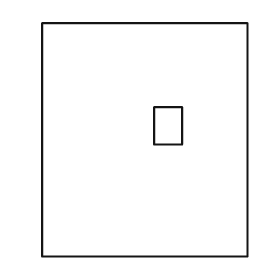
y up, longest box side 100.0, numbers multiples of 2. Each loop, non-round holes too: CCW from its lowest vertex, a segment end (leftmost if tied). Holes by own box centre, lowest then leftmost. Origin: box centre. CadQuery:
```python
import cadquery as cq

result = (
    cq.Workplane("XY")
    .moveTo(-44.0, -50.0)
    .lineTo(44.0, -50.0)
    .lineTo(44.0, 50.0)
    .lineTo(-44.0, 50.0)
    .close()
    .moveTo(4.0, -2.0)
    .lineTo(16.0, -2.0)
    .lineTo(16.0, 14.0)
    .lineTo(4.0, 14.0)
    .close()
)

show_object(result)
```